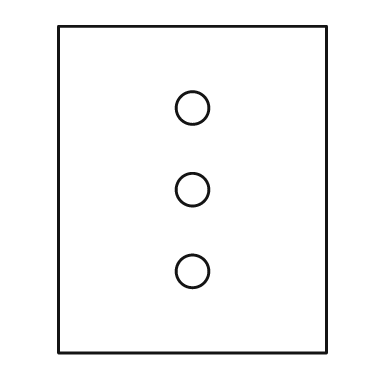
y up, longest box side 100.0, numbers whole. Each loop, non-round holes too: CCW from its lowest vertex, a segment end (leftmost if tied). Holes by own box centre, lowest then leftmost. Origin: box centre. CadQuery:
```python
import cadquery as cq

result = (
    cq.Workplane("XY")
    .moveTo(-41.0, -50.0)
    .lineTo(41.0, -50.0)
    .lineTo(41.0, 50.0)
    .lineTo(-41.0, 50.0)
    .close()
    .moveTo(0.0, -25.0)
    .circle(5.0)
    .moveTo(0.0, 0.0)
    .circle(5.0)
    .moveTo(0.0, 25.0)
    .circle(5.0)
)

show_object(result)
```